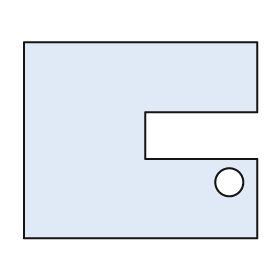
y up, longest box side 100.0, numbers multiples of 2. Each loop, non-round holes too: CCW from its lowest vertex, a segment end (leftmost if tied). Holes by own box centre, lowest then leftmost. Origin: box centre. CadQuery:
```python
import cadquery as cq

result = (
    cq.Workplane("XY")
    .moveTo(-50.0, -42.0)
    .lineTo(50.0, -42.0)
    .lineTo(50.0, -8.0)
    .lineTo(2.0, -8.0)
    .lineTo(2.0, 12.0)
    .lineTo(50.0, 12.0)
    .lineTo(50.0, 42.0)
    .lineTo(-50.0, 42.0)
    .close()
    .moveTo(38.0, -18.0)
    .circle(6.0)
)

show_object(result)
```